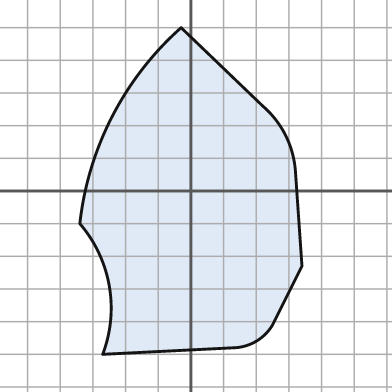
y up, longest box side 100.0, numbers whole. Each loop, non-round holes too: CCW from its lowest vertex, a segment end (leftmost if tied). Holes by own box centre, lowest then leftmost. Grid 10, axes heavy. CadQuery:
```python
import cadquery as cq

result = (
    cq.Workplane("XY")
    .moveTo(-27.0, -50.0)
    .lineTo(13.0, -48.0)
    .threePointArc((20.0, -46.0), (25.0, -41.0))
    .lineTo(34.0, -23.0)
    .lineTo(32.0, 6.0)
    .threePointArc((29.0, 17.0), (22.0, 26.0))
    .lineTo(-3.0, 50.0)
    .threePointArc((-24.0, 23.0), (-34.0, -10.0))
    .threePointArc((-25.0, -29.0), (-27.0, -50.0))
    .close()
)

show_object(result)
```